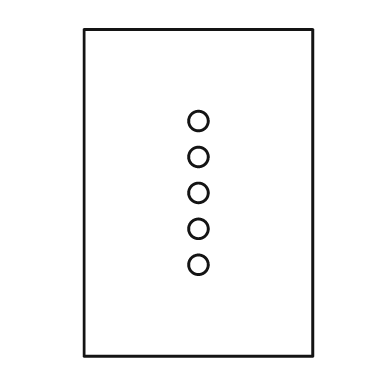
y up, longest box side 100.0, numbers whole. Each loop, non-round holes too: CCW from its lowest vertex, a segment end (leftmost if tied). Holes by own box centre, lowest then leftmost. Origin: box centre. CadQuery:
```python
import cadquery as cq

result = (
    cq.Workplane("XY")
    .moveTo(-35.0, -50.0)
    .lineTo(35.0, -50.0)
    .lineTo(35.0, 50.0)
    .lineTo(-35.0, 50.0)
    .close()
    .moveTo(0.0, -22.0)
    .circle(3.0)
    .moveTo(0.0, -11.0)
    .circle(3.0)
    .moveTo(0.0, 0.0)
    .circle(3.0)
    .moveTo(0.0, 11.0)
    .circle(3.0)
    .moveTo(0.0, 22.0)
    .circle(3.0)
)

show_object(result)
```